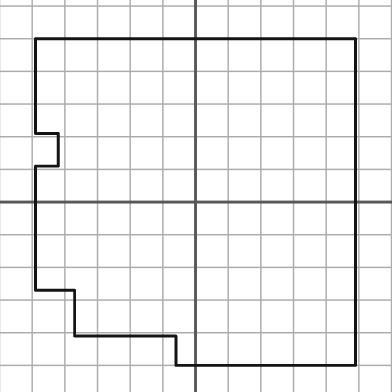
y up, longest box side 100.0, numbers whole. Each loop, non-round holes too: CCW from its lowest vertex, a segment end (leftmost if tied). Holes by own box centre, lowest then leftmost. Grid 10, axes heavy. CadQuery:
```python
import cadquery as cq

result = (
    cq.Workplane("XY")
    .moveTo(-6.0, -50.0)
    .lineTo(49.0, -50.0)
    .lineTo(49.0, 50.0)
    .lineTo(-49.0, 50.0)
    .lineTo(-49.0, 21.0)
    .lineTo(-42.0, 21.0)
    .lineTo(-42.0, 11.0)
    .lineTo(-49.0, 11.0)
    .lineTo(-49.0, -27.0)
    .lineTo(-37.0, -27.0)
    .lineTo(-37.0, -41.0)
    .lineTo(-6.0, -41.0)
    .close()
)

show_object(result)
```